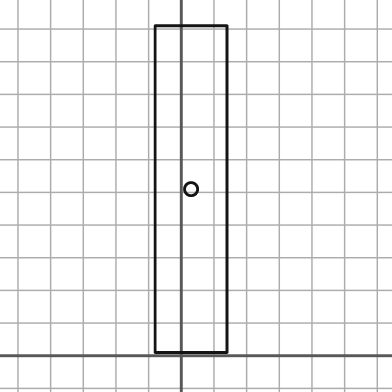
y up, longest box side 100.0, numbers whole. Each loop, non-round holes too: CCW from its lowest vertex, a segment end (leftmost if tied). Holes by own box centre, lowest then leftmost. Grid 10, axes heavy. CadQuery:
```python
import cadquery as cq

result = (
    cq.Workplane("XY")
    .moveTo(-8.0, 1.0)
    .lineTo(14.0, 1.0)
    .lineTo(14.0, 101.0)
    .lineTo(-8.0, 101.0)
    .close()
    .moveTo(3.0, 51.0)
    .circle(2.0)
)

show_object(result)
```